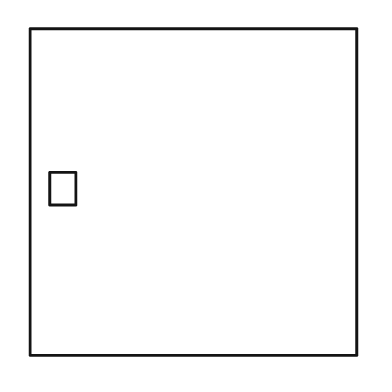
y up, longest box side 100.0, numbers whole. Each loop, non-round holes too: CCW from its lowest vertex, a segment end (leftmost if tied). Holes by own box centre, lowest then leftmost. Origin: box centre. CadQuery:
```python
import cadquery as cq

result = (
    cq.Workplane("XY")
    .moveTo(-50.0, -50.0)
    .lineTo(50.0, -50.0)
    .lineTo(50.0, 50.0)
    .lineTo(-50.0, 50.0)
    .close()
    .moveTo(-44.0, -4.0)
    .lineTo(-36.0, -4.0)
    .lineTo(-36.0, 6.0)
    .lineTo(-44.0, 6.0)
    .close()
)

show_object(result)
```